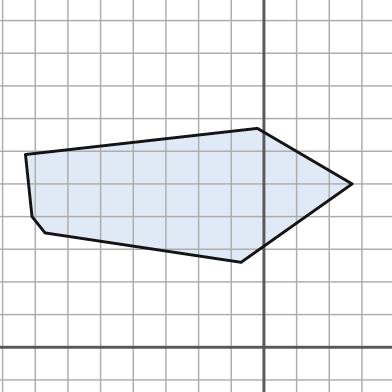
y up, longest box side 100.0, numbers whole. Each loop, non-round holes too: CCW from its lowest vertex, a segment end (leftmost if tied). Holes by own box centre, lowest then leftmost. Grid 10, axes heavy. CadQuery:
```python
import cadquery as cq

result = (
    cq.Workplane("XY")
    .moveTo(-7.0, 26.0)
    .lineTo(27.0, 50.0)
    .lineTo(-2.0, 67.0)
    .lineTo(-73.0, 59.0)
    .lineTo(-71.0, 40.0)
    .lineTo(-67.0, 35.0)
    .close()
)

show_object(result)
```